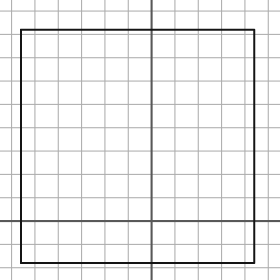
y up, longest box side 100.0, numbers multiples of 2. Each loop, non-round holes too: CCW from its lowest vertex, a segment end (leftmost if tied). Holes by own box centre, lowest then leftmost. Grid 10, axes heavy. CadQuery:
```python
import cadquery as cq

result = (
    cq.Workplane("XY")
    .moveTo(-56.0, -18.0)
    .lineTo(44.0, -18.0)
    .lineTo(44.0, 82.0)
    .lineTo(-56.0, 82.0)
    .close()
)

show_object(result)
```